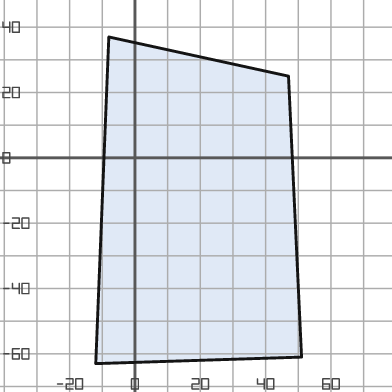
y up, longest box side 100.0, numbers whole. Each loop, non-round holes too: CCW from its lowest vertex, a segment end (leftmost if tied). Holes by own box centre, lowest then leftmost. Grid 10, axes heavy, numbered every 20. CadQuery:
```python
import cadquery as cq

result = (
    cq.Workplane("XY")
    .moveTo(-12.0, -63.0)
    .lineTo(51.0, -61.0)
    .lineTo(47.0, 25.0)
    .lineTo(-8.0, 37.0)
    .close()
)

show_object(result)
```